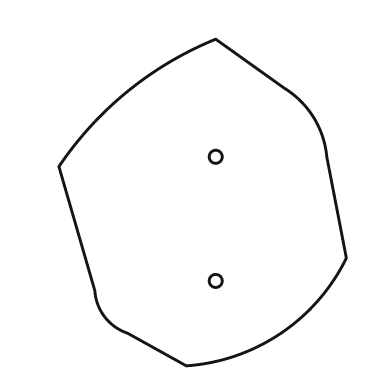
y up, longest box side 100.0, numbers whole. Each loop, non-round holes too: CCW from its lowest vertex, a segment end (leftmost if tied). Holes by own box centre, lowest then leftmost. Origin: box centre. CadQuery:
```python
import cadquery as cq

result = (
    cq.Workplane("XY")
    .moveTo(-5.0, -50.0)
    .threePointArc((24.0, -40.0), (44.0, -17.0))
    .lineTo(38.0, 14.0)
    .threePointArc((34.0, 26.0), (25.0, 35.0))
    .lineTo(4.0, 50.0)
    .threePointArc((-23.0, 34.0), (-44.0, 11.0))
    .lineTo(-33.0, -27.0)
    .threePointArc((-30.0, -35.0), (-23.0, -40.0))
    .close()
    .moveTo(4.0, -24.0)
    .circle(2.0)
    .moveTo(4.0, 14.0)
    .circle(2.0)
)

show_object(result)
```